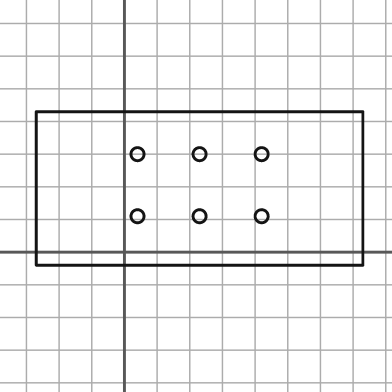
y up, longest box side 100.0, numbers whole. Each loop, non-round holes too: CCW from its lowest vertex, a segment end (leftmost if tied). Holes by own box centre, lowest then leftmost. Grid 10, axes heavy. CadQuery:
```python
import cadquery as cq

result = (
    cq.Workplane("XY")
    .moveTo(-27.0, -4.0)
    .lineTo(73.0, -4.0)
    .lineTo(73.0, 43.0)
    .lineTo(-27.0, 43.0)
    .close()
    .moveTo(4.0, 11.0)
    .circle(2.0)
    .moveTo(23.0, 11.0)
    .circle(2.0)
    .moveTo(42.0, 11.0)
    .circle(2.0)
    .moveTo(4.0, 30.0)
    .circle(2.0)
    .moveTo(23.0, 30.0)
    .circle(2.0)
    .moveTo(42.0, 30.0)
    .circle(2.0)
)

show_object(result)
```